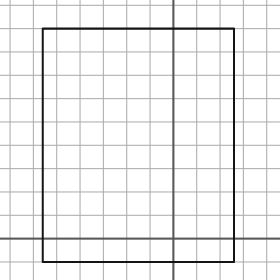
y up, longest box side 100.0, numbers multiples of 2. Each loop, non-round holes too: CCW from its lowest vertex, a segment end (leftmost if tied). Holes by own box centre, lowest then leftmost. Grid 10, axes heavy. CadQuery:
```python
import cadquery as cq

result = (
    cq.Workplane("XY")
    .moveTo(-56.0, -10.0)
    .lineTo(26.0, -10.0)
    .lineTo(26.0, 90.0)
    .lineTo(-56.0, 90.0)
    .close()
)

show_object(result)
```